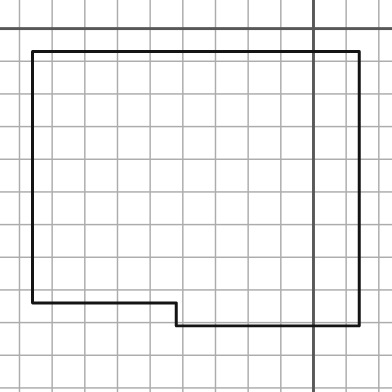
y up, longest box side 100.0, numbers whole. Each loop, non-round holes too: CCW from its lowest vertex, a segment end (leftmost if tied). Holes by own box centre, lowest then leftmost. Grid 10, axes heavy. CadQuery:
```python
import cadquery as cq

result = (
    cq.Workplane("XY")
    .moveTo(-42.0, -91.0)
    .lineTo(14.0, -91.0)
    .lineTo(14.0, -7.0)
    .lineTo(-86.0, -7.0)
    .lineTo(-86.0, -84.0)
    .lineTo(-42.0, -84.0)
    .close()
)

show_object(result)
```